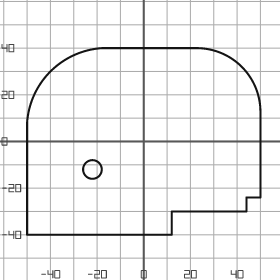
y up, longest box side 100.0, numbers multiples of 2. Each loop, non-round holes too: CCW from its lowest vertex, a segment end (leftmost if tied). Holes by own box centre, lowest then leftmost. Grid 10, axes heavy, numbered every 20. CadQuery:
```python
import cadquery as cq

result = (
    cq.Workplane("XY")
    .moveTo(-50.0, -40.0)
    .lineTo(12.0, -40.0)
    .lineTo(12.0, -30.0)
    .lineTo(44.0, -30.0)
    .lineTo(44.0, -24.0)
    .lineTo(50.0, -24.0)
    .lineTo(50.0, 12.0)
    .threePointArc((42.0, 32.0), (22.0, 40.0))
    .lineTo(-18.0, 40.0)
    .threePointArc((-40.0, 30.0), (-50.0, 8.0))
    .close()
    .moveTo(-22.0, -12.0)
    .circle(4.0)
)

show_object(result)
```